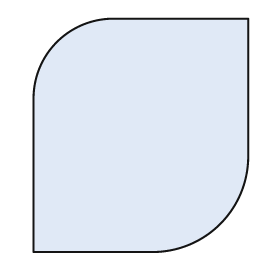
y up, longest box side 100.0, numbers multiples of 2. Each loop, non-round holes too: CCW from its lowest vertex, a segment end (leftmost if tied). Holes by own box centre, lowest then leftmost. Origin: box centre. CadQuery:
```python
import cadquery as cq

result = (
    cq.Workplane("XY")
    .moveTo(-46.0, -50.0)
    .lineTo(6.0, -50.0)
    .threePointArc((34.0, -38.0), (46.0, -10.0))
    .lineTo(46.0, 50.0)
    .lineTo(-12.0, 50.0)
    .threePointArc((-36.0, 40.0), (-46.0, 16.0))
    .close()
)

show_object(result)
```